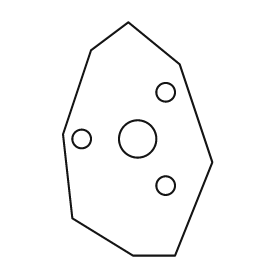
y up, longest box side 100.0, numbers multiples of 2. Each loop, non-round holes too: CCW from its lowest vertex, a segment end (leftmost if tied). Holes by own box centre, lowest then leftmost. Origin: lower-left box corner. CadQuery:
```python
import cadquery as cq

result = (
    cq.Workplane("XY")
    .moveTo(30.0, 0.0)
    .lineTo(48.0, 0.0)
    .lineTo(64.0, 40.0)
    .lineTo(50.0, 82.0)
    .lineTo(28.0, 100.0)
    .lineTo(12.0, 88.0)
    .lineTo(0.0, 52.0)
    .lineTo(4.0, 16.0)
    .close()
    .moveTo(44.0, 30.0)
    .circle(4.0)
    .moveTo(8.0, 50.0)
    .circle(4.0)
    .moveTo(32.0, 50.0)
    .circle(8.0)
    .moveTo(44.0, 70.0)
    .circle(4.0)
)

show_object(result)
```